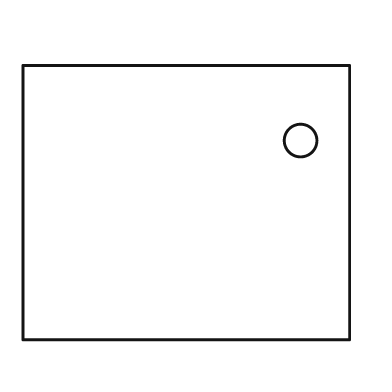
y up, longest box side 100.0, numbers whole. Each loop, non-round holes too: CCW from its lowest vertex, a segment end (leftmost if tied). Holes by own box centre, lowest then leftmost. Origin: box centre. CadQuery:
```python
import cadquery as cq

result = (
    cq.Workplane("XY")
    .moveTo(-50.0, -42.0)
    .lineTo(50.0, -42.0)
    .lineTo(50.0, 42.0)
    .lineTo(-50.0, 42.0)
    .close()
    .moveTo(35.0, 19.0)
    .circle(5.0)
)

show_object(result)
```